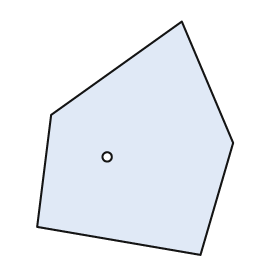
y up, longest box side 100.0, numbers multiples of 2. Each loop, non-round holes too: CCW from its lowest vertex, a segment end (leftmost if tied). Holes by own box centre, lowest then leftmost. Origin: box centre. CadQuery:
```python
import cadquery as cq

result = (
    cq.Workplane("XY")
    .moveTo(28.0, -50.0)
    .lineTo(42.0, -2.0)
    .lineTo(20.0, 50.0)
    .lineTo(-36.0, 10.0)
    .lineTo(-42.0, -38.0)
    .close()
    .moveTo(-12.0, -8.0)
    .circle(2.0)
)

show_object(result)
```